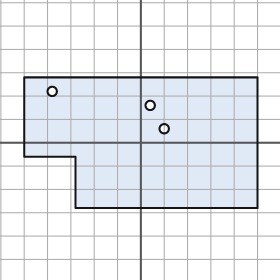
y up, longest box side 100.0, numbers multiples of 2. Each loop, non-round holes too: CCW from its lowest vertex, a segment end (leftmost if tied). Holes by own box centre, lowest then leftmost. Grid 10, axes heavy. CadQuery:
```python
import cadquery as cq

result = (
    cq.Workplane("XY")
    .moveTo(-28.0, -28.0)
    .lineTo(50.0, -28.0)
    .lineTo(50.0, 28.0)
    .lineTo(-50.0, 28.0)
    .lineTo(-50.0, -6.0)
    .lineTo(-28.0, -6.0)
    .close()
    .moveTo(10.0, 6.0)
    .circle(2.0)
    .moveTo(4.0, 16.0)
    .circle(2.0)
    .moveTo(-38.0, 22.0)
    .circle(2.0)
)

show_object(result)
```